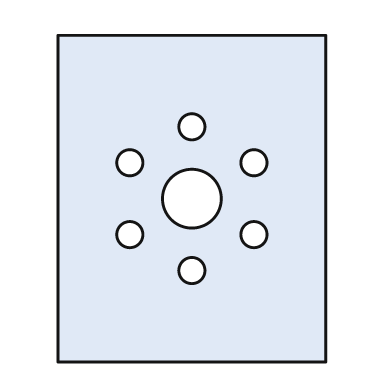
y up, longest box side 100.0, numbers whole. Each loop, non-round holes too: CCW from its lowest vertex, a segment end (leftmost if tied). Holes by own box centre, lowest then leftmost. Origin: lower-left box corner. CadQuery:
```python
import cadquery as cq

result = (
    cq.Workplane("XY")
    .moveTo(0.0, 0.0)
    .lineTo(82.0, 0.0)
    .lineTo(82.0, 100.0)
    .lineTo(0.0, 100.0)
    .close()
    .moveTo(41.0, 28.0)
    .circle(4.0)
    .moveTo(22.0, 39.0)
    .circle(4.0)
    .moveTo(60.0, 39.0)
    .circle(4.0)
    .moveTo(41.0, 50.0)
    .circle(9.0)
    .moveTo(22.0, 61.0)
    .circle(4.0)
    .moveTo(60.0, 61.0)
    .circle(4.0)
    .moveTo(41.0, 72.0)
    .circle(4.0)
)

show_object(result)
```